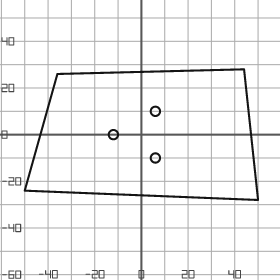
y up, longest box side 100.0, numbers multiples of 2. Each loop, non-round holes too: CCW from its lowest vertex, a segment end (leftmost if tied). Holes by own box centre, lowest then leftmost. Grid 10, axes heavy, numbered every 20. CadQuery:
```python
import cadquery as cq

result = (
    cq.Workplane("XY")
    .moveTo(50.0, -28.0)
    .lineTo(44.0, 28.0)
    .lineTo(-36.0, 26.0)
    .lineTo(-50.0, -24.0)
    .close()
    .moveTo(6.0, -10.0)
    .circle(2.0)
    .moveTo(-12.0, 0.0)
    .circle(2.0)
    .moveTo(6.0, 10.0)
    .circle(2.0)
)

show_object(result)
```